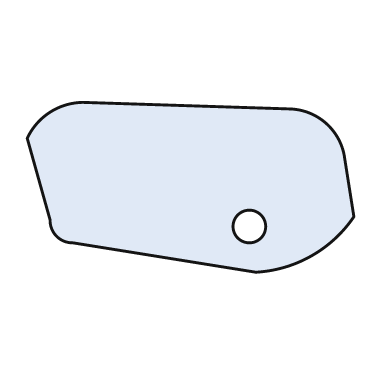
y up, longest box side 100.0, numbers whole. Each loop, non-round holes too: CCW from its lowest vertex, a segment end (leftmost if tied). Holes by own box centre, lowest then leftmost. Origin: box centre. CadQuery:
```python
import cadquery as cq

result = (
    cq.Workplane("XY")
    .moveTo(20.0, -26.0)
    .threePointArc((37.0, -21.0), (50.0, -9.0))
    .lineTo(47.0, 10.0)
    .threePointArc((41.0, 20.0), (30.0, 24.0))
    .lineTo(-33.0, 26.0)
    .threePointArc((-43.0, 23.0), (-50.0, 15.0))
    .lineTo(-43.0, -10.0)
    .threePointArc((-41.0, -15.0), (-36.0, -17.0))
    .close()
    .moveTo(18.0, -12.0)
    .circle(5.0)
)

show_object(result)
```